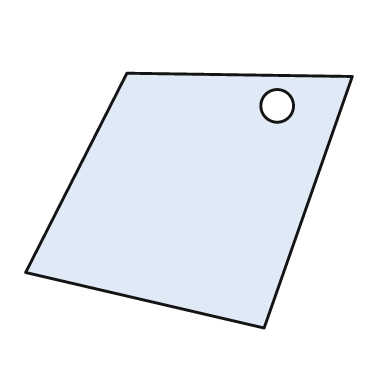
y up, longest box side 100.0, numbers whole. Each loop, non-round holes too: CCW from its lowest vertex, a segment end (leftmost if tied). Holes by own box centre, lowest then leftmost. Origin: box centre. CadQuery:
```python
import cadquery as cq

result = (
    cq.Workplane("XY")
    .moveTo(23.0, -39.0)
    .lineTo(50.0, 38.0)
    .lineTo(-19.0, 39.0)
    .lineTo(-50.0, -22.0)
    .close()
    .moveTo(27.0, 29.0)
    .circle(5.0)
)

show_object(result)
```